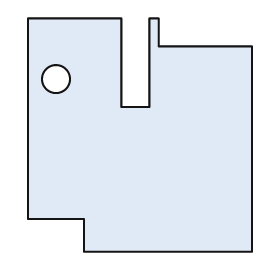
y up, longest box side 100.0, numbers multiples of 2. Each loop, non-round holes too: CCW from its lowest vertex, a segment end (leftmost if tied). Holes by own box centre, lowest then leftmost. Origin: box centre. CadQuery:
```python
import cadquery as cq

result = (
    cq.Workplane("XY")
    .moveTo(-24.0, -50.0)
    .lineTo(48.0, -50.0)
    .lineTo(48.0, 38.0)
    .lineTo(8.0, 38.0)
    .lineTo(8.0, 50.0)
    .lineTo(4.0, 50.0)
    .lineTo(4.0, 12.0)
    .lineTo(-8.0, 12.0)
    .lineTo(-8.0, 50.0)
    .lineTo(-48.0, 50.0)
    .lineTo(-48.0, -36.0)
    .lineTo(-24.0, -36.0)
    .close()
    .moveTo(-36.0, 24.0)
    .circle(6.0)
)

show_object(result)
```